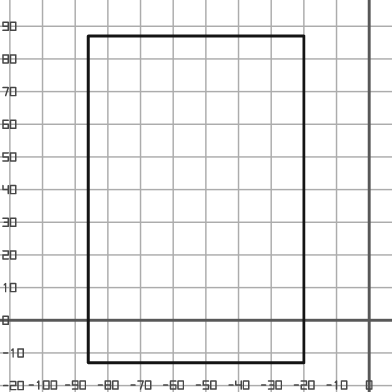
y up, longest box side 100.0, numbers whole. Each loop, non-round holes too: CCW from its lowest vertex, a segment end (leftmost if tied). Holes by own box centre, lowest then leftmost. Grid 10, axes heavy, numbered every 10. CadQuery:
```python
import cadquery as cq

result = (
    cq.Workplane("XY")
    .moveTo(-86.0, -13.0)
    .lineTo(-20.0, -13.0)
    .lineTo(-20.0, 87.0)
    .lineTo(-86.0, 87.0)
    .close()
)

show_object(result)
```